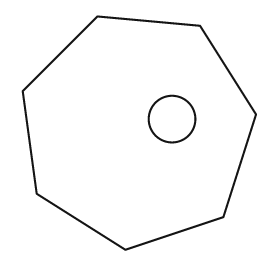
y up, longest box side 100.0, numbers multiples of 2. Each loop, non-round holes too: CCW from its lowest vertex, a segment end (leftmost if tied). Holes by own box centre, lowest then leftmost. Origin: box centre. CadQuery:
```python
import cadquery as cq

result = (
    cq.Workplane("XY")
    .moveTo(-6.0, -50.0)
    .lineTo(36.0, -36.0)
    .lineTo(50.0, 8.0)
    .lineTo(26.0, 46.0)
    .lineTo(-18.0, 50.0)
    .lineTo(-50.0, 18.0)
    .lineTo(-44.0, -26.0)
    .close()
    .moveTo(14.0, 6.0)
    .circle(10.0)
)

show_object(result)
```